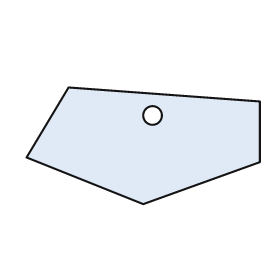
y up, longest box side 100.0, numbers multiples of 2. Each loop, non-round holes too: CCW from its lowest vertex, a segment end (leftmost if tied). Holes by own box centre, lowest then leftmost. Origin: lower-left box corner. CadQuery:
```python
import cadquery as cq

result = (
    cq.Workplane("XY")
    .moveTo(50.0, 0.0)
    .lineTo(100.0, 18.0)
    .lineTo(100.0, 44.0)
    .lineTo(18.0, 50.0)
    .lineTo(0.0, 20.0)
    .close()
    .moveTo(54.0, 38.0)
    .circle(4.0)
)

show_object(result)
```